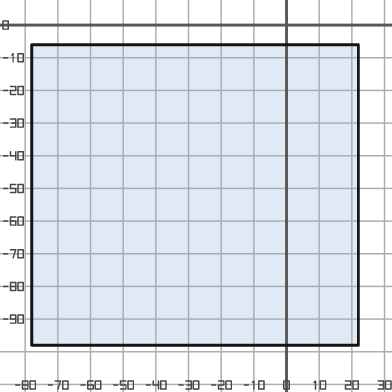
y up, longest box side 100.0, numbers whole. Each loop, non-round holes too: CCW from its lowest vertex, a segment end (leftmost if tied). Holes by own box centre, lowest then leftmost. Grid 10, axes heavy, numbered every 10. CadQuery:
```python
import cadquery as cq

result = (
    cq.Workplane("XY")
    .moveTo(-78.0, -98.0)
    .lineTo(22.0, -98.0)
    .lineTo(22.0, -6.0)
    .lineTo(-78.0, -6.0)
    .close()
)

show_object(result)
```